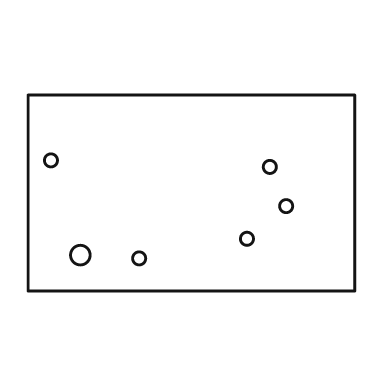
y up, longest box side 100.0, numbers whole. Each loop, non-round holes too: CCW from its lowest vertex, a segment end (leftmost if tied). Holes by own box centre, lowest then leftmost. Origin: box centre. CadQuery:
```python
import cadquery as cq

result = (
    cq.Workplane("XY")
    .moveTo(-50.0, -30.0)
    .lineTo(50.0, -30.0)
    .lineTo(50.0, 30.0)
    .lineTo(-50.0, 30.0)
    .close()
    .moveTo(-16.0, -20.0)
    .circle(2.0)
    .moveTo(-34.0, -19.0)
    .circle(3.0)
    .moveTo(17.0, -14.0)
    .circle(2.0)
    .moveTo(29.0, -4.0)
    .circle(2.0)
    .moveTo(24.0, 8.0)
    .circle(2.0)
    .moveTo(-43.0, 10.0)
    .circle(2.0)
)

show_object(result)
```